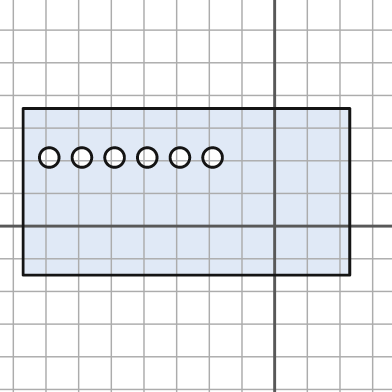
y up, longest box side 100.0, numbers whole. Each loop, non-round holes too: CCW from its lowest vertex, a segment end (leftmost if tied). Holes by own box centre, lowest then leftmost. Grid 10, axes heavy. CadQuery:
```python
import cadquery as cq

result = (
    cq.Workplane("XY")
    .moveTo(-77.0, -15.0)
    .lineTo(23.0, -15.0)
    .lineTo(23.0, 36.0)
    .lineTo(-77.0, 36.0)
    .close()
    .moveTo(-69.0, 21.0)
    .circle(3.0)
    .moveTo(-59.0, 21.0)
    .circle(3.0)
    .moveTo(-49.0, 21.0)
    .circle(3.0)
    .moveTo(-39.0, 21.0)
    .circle(3.0)
    .moveTo(-29.0, 21.0)
    .circle(3.0)
    .moveTo(-19.0, 21.0)
    .circle(3.0)
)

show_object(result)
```